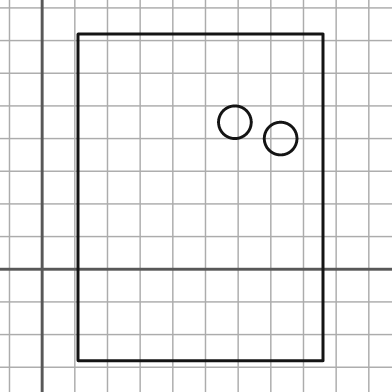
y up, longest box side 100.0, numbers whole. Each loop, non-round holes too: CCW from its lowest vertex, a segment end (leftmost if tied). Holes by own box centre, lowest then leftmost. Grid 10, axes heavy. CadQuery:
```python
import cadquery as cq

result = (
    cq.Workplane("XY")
    .moveTo(11.0, -28.0)
    .lineTo(86.0, -28.0)
    .lineTo(86.0, 72.0)
    .lineTo(11.0, 72.0)
    .close()
    .moveTo(73.0, 40.0)
    .circle(5.0)
    .moveTo(59.0, 45.0)
    .circle(5.0)
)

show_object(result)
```